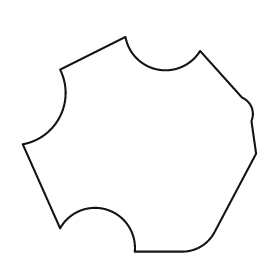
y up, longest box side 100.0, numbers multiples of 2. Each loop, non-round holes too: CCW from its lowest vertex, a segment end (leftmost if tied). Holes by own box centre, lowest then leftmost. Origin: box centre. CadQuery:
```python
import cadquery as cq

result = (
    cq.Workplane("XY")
    .moveTo(-2.0, -46.0)
    .lineTo(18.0, -46.0)
    .threePointArc((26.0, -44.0), (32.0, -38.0))
    .lineTo(50.0, -4.0)
    .lineTo(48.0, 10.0)
    .threePointArc((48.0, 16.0), (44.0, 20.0))
    .lineTo(26.0, 40.0)
    .threePointArc((8.0, 32.0), (-6.0, 46.0))
    .lineTo(-34.0, 32.0)
    .threePointArc((-34.0, 12.0), (-50.0, 0.0))
    .lineTo(-34.0, -36.0)
    .threePointArc((-14.0, -28.0), (-2.0, -46.0))
    .close()
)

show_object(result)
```